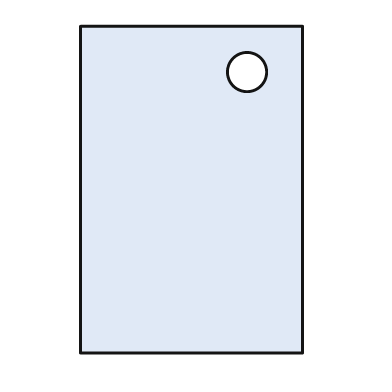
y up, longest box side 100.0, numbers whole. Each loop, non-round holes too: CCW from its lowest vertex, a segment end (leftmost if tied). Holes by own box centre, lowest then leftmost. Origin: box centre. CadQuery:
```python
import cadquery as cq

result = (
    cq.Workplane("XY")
    .moveTo(-34.0, -50.0)
    .lineTo(34.0, -50.0)
    .lineTo(34.0, 50.0)
    .lineTo(-34.0, 50.0)
    .close()
    .moveTo(17.0, 36.0)
    .circle(6.0)
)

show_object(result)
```